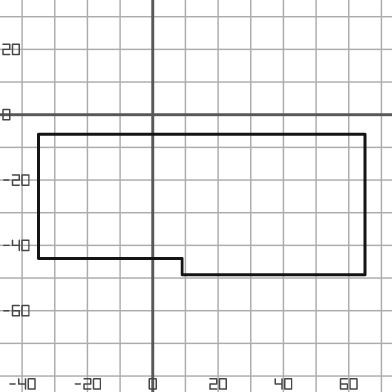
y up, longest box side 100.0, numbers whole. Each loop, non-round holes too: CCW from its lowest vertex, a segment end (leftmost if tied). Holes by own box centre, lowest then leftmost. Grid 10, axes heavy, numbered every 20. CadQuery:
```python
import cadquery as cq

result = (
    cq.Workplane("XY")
    .moveTo(9.0, -49.0)
    .lineTo(65.0, -49.0)
    .lineTo(65.0, -6.0)
    .lineTo(-35.0, -6.0)
    .lineTo(-35.0, -44.0)
    .lineTo(9.0, -44.0)
    .close()
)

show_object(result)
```